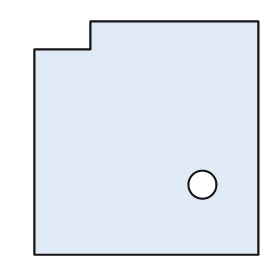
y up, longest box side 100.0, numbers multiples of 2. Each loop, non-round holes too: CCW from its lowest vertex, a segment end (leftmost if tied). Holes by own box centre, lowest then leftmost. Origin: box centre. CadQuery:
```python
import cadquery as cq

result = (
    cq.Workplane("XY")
    .moveTo(-48.0, -50.0)
    .lineTo(48.0, -50.0)
    .lineTo(48.0, 50.0)
    .lineTo(-24.0, 50.0)
    .lineTo(-24.0, 38.0)
    .lineTo(-48.0, 38.0)
    .close()
    .moveTo(24.0, -20.0)
    .circle(6.0)
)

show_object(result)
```